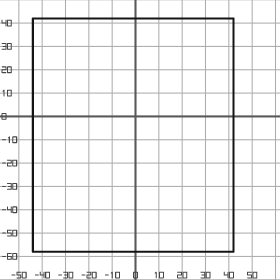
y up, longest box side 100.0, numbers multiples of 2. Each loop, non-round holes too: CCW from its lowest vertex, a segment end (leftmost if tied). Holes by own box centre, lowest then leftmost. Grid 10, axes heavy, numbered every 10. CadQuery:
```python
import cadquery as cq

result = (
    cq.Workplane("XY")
    .moveTo(-44.0, -58.0)
    .lineTo(42.0, -58.0)
    .lineTo(42.0, 42.0)
    .lineTo(-44.0, 42.0)
    .close()
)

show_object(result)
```